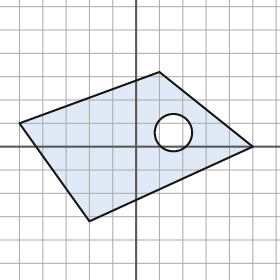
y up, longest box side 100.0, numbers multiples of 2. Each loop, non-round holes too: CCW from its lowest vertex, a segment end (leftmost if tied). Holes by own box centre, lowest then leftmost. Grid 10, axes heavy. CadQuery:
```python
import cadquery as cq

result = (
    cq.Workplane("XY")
    .moveTo(-20.0, -32.0)
    .lineTo(50.0, 0.0)
    .lineTo(10.0, 32.0)
    .lineTo(-50.0, 10.0)
    .close()
    .moveTo(16.0, 6.0)
    .circle(8.0)
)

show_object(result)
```